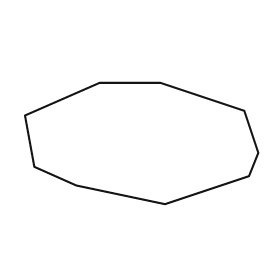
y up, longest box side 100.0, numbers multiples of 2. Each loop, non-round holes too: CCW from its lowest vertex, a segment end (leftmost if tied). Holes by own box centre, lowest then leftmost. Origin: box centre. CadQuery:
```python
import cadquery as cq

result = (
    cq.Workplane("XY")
    .moveTo(10.0, -26.0)
    .lineTo(46.0, -14.0)
    .lineTo(50.0, -4.0)
    .lineTo(44.0, 14.0)
    .lineTo(8.0, 26.0)
    .lineTo(-18.0, 26.0)
    .lineTo(-50.0, 12.0)
    .lineTo(-46.0, -10.0)
    .lineTo(-28.0, -18.0)
    .close()
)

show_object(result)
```